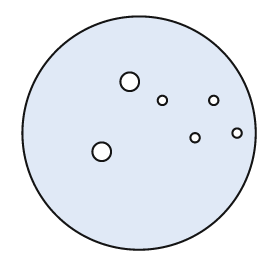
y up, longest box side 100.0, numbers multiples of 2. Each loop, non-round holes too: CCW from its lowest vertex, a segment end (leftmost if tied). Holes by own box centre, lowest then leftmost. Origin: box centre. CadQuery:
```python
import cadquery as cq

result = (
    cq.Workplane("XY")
    .moveTo(0.0, 0.0)
    .circle(50.0)
    .moveTo(-16.0, -8.0)
    .circle(4.0)
    .moveTo(24.0, -2.0)
    .circle(2.0)
    .moveTo(42.0, 0.0)
    .circle(2.0)
    .moveTo(10.0, 14.0)
    .circle(2.0)
    .moveTo(32.0, 14.0)
    .circle(2.0)
    .moveTo(-4.0, 22.0)
    .circle(4.0)
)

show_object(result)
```